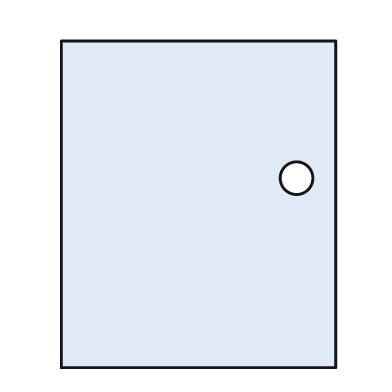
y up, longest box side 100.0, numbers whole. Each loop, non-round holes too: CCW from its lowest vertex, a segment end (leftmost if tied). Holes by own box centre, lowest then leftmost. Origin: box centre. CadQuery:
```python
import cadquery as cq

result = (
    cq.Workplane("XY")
    .moveTo(-42.0, -50.0)
    .lineTo(42.0, -50.0)
    .lineTo(42.0, 50.0)
    .lineTo(-42.0, 50.0)
    .close()
    .moveTo(30.0, 8.0)
    .circle(5.0)
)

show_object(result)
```